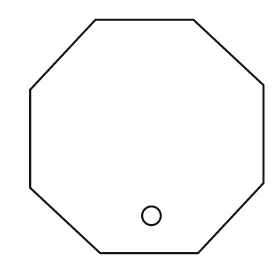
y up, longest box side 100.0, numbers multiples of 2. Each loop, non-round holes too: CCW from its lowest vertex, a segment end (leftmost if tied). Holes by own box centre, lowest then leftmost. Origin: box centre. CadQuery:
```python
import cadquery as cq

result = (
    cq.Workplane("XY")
    .moveTo(-20.0, -50.0)
    .lineTo(22.0, -50.0)
    .lineTo(50.0, -20.0)
    .lineTo(50.0, 22.0)
    .lineTo(20.0, 50.0)
    .lineTo(-22.0, 50.0)
    .lineTo(-50.0, 20.0)
    .lineTo(-50.0, -22.0)
    .close()
    .moveTo(2.0, -34.0)
    .circle(4.0)
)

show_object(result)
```